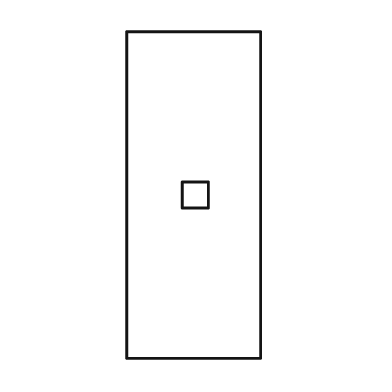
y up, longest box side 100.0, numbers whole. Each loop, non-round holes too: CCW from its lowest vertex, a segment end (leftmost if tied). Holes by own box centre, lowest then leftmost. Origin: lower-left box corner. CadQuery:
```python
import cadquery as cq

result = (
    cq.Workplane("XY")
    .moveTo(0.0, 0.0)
    .lineTo(41.0, 0.0)
    .lineTo(41.0, 100.0)
    .lineTo(0.0, 100.0)
    .close()
    .moveTo(17.0, 46.0)
    .lineTo(25.0, 46.0)
    .lineTo(25.0, 54.0)
    .lineTo(17.0, 54.0)
    .close()
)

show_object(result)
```